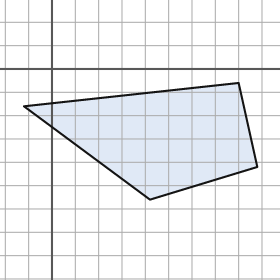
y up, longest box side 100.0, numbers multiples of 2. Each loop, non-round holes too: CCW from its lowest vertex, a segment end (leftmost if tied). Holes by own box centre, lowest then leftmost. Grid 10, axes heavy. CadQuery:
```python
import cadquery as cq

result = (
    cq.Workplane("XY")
    .moveTo(42.0, -56.0)
    .lineTo(88.0, -42.0)
    .lineTo(80.0, -6.0)
    .lineTo(-12.0, -16.0)
    .close()
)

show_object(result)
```